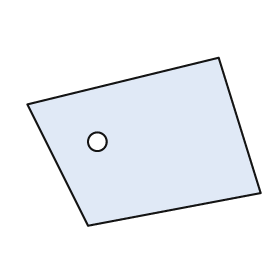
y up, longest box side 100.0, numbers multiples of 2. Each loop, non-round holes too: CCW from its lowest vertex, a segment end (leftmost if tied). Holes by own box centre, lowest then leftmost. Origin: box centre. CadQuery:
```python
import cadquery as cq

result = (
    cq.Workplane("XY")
    .moveTo(-24.0, -36.0)
    .lineTo(50.0, -22.0)
    .lineTo(32.0, 36.0)
    .lineTo(-50.0, 16.0)
    .close()
    .moveTo(-20.0, 0.0)
    .circle(4.0)
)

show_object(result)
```